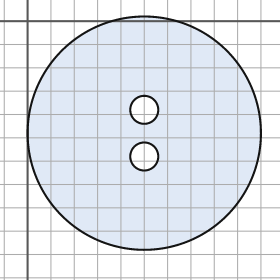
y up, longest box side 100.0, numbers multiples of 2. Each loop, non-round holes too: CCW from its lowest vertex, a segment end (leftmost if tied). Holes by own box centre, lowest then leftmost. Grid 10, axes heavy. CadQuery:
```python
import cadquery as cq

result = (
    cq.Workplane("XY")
    .moveTo(50.0, -48.0)
    .circle(50.0)
    .moveTo(50.0, -58.0)
    .circle(6.0)
    .moveTo(50.0, -38.0)
    .circle(6.0)
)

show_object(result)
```